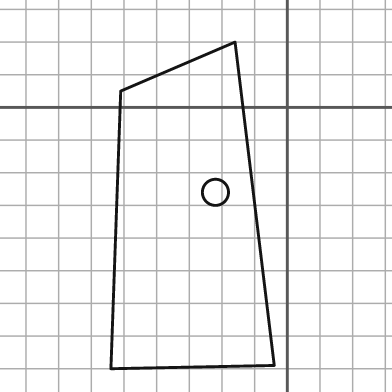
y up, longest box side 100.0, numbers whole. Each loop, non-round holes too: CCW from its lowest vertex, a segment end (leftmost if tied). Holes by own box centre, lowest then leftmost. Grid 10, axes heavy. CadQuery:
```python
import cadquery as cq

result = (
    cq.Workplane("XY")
    .moveTo(-54.0, -80.0)
    .lineTo(-4.0, -79.0)
    .lineTo(-16.0, 20.0)
    .lineTo(-51.0, 5.0)
    .close()
    .moveTo(-22.0, -26.0)
    .circle(4.0)
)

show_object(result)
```